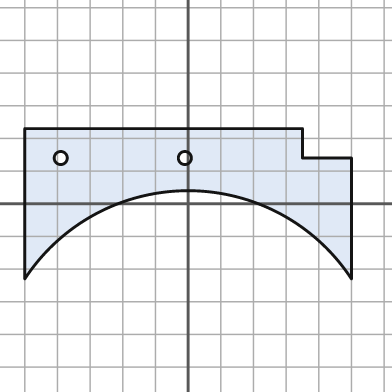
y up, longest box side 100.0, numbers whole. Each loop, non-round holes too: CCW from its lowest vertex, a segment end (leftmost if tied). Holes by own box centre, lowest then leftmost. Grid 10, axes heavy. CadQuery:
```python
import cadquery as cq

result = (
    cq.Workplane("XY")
    .moveTo(-50.0, -23.0)
    .threePointArc((0.0, 4.0), (50.0, -23.0))
    .lineTo(50.0, 14.0)
    .lineTo(35.0, 14.0)
    .lineTo(35.0, 23.0)
    .lineTo(-50.0, 23.0)
    .close()
    .moveTo(-39.0, 14.0)
    .circle(2.0)
    .moveTo(-1.0, 14.0)
    .circle(2.0)
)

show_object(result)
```